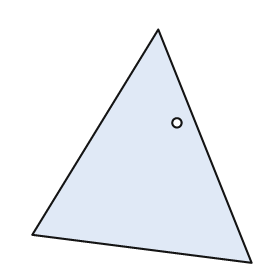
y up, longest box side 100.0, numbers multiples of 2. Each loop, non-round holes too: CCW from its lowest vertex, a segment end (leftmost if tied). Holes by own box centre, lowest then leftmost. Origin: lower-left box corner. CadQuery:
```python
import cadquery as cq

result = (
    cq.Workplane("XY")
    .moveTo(94.0, 0.0)
    .lineTo(54.0, 100.0)
    .lineTo(0.0, 12.0)
    .close()
    .moveTo(62.0, 60.0)
    .circle(2.0)
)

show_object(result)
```